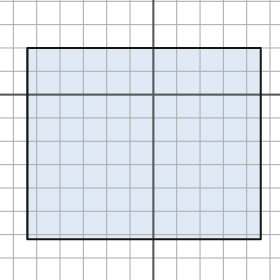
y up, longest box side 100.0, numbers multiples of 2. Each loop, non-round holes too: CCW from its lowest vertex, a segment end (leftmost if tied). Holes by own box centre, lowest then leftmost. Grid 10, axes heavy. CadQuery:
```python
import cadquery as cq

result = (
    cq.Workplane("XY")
    .moveTo(-54.0, -62.0)
    .lineTo(46.0, -62.0)
    .lineTo(46.0, 20.0)
    .lineTo(-54.0, 20.0)
    .close()
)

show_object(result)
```